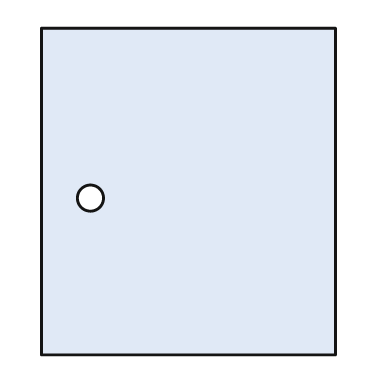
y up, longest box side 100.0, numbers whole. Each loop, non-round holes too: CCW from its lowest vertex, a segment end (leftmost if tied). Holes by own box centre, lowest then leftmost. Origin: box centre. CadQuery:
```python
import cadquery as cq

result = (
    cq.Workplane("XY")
    .moveTo(-45.0, -50.0)
    .lineTo(45.0, -50.0)
    .lineTo(45.0, 50.0)
    .lineTo(-45.0, 50.0)
    .close()
    .moveTo(-30.0, -2.0)
    .circle(4.0)
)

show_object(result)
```